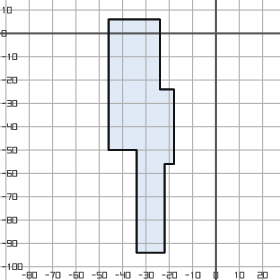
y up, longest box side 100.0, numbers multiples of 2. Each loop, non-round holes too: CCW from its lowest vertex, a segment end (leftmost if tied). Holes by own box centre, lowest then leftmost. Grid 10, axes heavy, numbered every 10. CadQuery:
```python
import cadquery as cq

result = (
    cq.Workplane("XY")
    .moveTo(-34.0, -94.0)
    .lineTo(-22.0, -94.0)
    .lineTo(-22.0, -56.0)
    .lineTo(-18.0, -56.0)
    .lineTo(-18.0, -24.0)
    .lineTo(-24.0, -24.0)
    .lineTo(-24.0, 6.0)
    .lineTo(-46.0, 6.0)
    .lineTo(-46.0, -50.0)
    .lineTo(-34.0, -50.0)
    .close()
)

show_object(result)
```